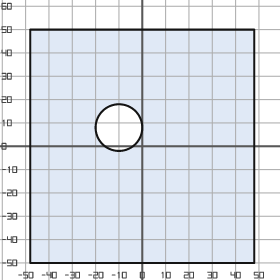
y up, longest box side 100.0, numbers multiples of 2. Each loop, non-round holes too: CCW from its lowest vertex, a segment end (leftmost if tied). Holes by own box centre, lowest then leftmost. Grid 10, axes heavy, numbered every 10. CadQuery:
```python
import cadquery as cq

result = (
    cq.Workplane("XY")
    .moveTo(-48.0, -50.0)
    .lineTo(48.0, -50.0)
    .lineTo(48.0, 50.0)
    .lineTo(-48.0, 50.0)
    .close()
    .moveTo(-10.0, 8.0)
    .circle(10.0)
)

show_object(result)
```